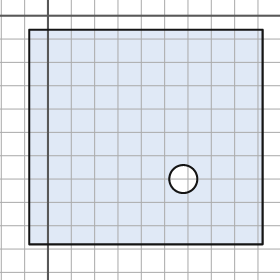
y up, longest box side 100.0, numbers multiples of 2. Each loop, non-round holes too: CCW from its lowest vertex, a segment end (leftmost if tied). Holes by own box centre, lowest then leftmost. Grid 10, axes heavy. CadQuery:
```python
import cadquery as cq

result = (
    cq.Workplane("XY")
    .moveTo(-8.0, -98.0)
    .lineTo(92.0, -98.0)
    .lineTo(92.0, -6.0)
    .lineTo(-8.0, -6.0)
    .close()
    .moveTo(58.0, -70.0)
    .circle(6.0)
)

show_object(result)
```